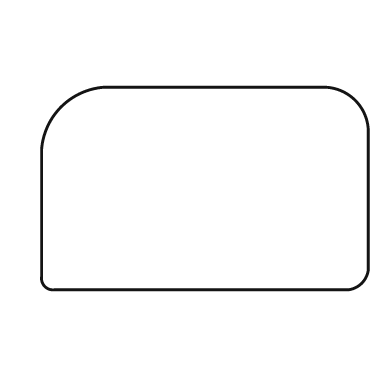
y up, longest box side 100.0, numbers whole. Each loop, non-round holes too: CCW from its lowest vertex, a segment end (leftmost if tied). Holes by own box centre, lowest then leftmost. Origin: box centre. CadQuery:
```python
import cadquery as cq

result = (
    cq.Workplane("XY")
    .moveTo(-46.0, -31.0)
    .lineTo(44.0, -31.0)
    .threePointArc((48.0, -29.0), (50.0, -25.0))
    .lineTo(50.0, 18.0)
    .threePointArc((46.0, 27.0), (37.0, 31.0))
    .lineTo(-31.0, 31.0)
    .threePointArc((-44.0, 25.0), (-50.0, 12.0))
    .lineTo(-50.0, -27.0)
    .threePointArc((-49.0, -30.0), (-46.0, -31.0))
    .close()
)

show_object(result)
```